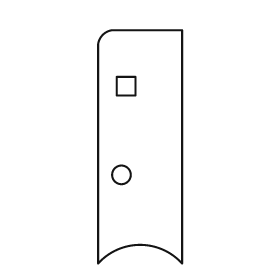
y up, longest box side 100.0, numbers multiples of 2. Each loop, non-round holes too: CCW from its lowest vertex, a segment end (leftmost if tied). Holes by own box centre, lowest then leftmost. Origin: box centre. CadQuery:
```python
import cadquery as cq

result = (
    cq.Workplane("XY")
    .moveTo(-18.0, -50.0)
    .threePointArc((0.0, -42.0), (18.0, -50.0))
    .lineTo(18.0, 50.0)
    .lineTo(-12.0, 50.0)
    .threePointArc((-16.0, 48.0), (-18.0, 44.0))
    .close()
    .moveTo(-8.0, -12.0)
    .circle(4.0)
    .moveTo(-10.0, 22.0)
    .lineTo(-2.0, 22.0)
    .lineTo(-2.0, 30.0)
    .lineTo(-10.0, 30.0)
    .close()
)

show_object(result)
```